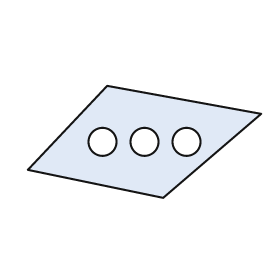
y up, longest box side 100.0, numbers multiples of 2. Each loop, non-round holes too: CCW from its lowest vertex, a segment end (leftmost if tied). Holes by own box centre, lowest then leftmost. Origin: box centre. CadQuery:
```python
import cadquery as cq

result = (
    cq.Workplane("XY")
    .moveTo(8.0, -24.0)
    .lineTo(50.0, 12.0)
    .lineTo(-16.0, 24.0)
    .lineTo(-50.0, -12.0)
    .close()
    .moveTo(-18.0, 0.0)
    .circle(6.0)
    .moveTo(0.0, 0.0)
    .circle(6.0)
    .moveTo(18.0, 0.0)
    .circle(6.0)
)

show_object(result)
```